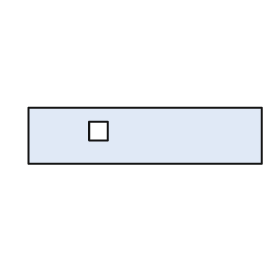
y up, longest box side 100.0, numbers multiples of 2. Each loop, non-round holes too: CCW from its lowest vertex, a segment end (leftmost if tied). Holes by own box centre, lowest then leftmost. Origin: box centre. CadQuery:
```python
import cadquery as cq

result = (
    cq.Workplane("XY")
    .moveTo(-50.0, -12.0)
    .lineTo(50.0, -12.0)
    .lineTo(50.0, 12.0)
    .lineTo(-50.0, 12.0)
    .close()
    .moveTo(-24.0, -2.0)
    .lineTo(-16.0, -2.0)
    .lineTo(-16.0, 6.0)
    .lineTo(-24.0, 6.0)
    .close()
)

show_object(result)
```